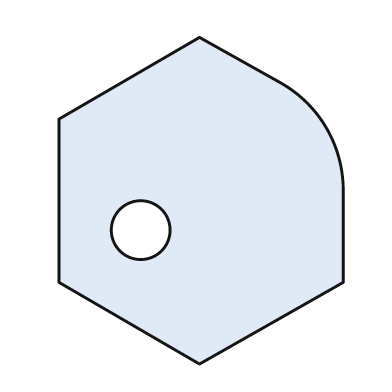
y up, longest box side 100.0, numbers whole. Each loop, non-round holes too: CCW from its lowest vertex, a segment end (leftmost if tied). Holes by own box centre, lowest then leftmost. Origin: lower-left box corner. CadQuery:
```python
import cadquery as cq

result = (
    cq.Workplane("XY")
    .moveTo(43.0, 0.0)
    .lineTo(87.0, 25.0)
    .lineTo(87.0, 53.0)
    .threePointArc((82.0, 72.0), (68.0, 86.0))
    .lineTo(43.0, 100.0)
    .lineTo(0.0, 75.0)
    .lineTo(0.0, 25.0)
    .close()
    .moveTo(25.0, 41.0)
    .circle(9.0)
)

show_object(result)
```